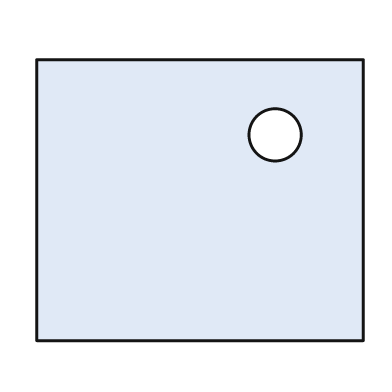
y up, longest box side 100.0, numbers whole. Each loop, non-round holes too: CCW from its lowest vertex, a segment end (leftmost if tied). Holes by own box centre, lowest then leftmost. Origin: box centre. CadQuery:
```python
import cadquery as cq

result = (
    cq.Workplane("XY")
    .moveTo(-50.0, -43.0)
    .lineTo(50.0, -43.0)
    .lineTo(50.0, 43.0)
    .lineTo(-50.0, 43.0)
    .close()
    .moveTo(23.0, 20.0)
    .circle(8.0)
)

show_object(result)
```